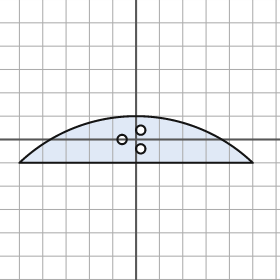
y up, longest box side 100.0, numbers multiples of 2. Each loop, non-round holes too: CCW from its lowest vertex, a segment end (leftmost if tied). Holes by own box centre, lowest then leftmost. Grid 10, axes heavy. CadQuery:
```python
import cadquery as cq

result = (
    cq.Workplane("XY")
    .moveTo(-50.0, -10.0)
    .lineTo(50.0, -10.0)
    .threePointArc((0.0, 10.0), (-50.0, -10.0))
    .close()
    .moveTo(2.0, -4.0)
    .circle(2.0)
    .moveTo(-6.0, 0.0)
    .circle(2.0)
    .moveTo(2.0, 4.0)
    .circle(2.0)
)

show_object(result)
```